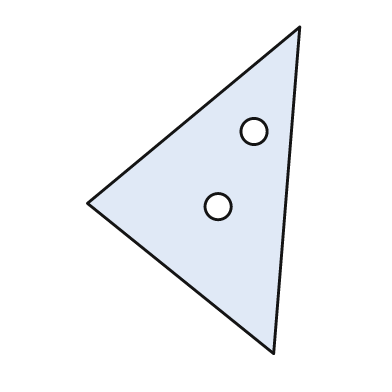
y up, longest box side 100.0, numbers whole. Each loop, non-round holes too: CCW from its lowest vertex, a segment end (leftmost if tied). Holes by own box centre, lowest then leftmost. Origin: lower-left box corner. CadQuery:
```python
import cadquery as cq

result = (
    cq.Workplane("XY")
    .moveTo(57.0, 0.0)
    .lineTo(65.0, 100.0)
    .lineTo(0.0, 46.0)
    .close()
    .moveTo(40.0, 45.0)
    .circle(4.0)
    .moveTo(51.0, 68.0)
    .circle(4.0)
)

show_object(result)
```